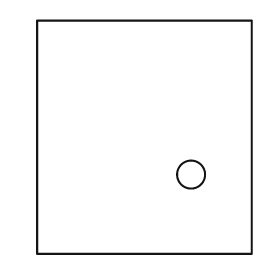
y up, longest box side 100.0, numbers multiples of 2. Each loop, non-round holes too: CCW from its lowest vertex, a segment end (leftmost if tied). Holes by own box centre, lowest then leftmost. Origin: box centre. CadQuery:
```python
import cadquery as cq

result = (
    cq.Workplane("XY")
    .moveTo(-46.0, -50.0)
    .lineTo(46.0, -50.0)
    .lineTo(46.0, 50.0)
    .lineTo(-46.0, 50.0)
    .close()
    .moveTo(20.0, -16.0)
    .circle(6.0)
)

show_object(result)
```